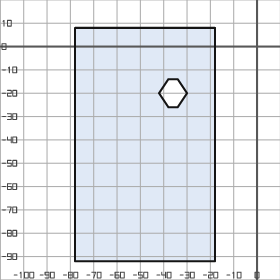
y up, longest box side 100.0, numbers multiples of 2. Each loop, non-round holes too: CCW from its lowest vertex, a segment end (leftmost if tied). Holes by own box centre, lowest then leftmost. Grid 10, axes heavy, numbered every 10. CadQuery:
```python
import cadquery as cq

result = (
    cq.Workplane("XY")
    .moveTo(-78.0, -92.0)
    .lineTo(-18.0, -92.0)
    .lineTo(-18.0, 8.0)
    .lineTo(-78.0, 8.0)
    .close()
    .moveTo(-38.0, -26.0)
    .lineTo(-34.0, -26.0)
    .lineTo(-30.0, -20.0)
    .lineTo(-34.0, -14.0)
    .lineTo(-38.0, -14.0)
    .lineTo(-42.0, -20.0)
    .close()
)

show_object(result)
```